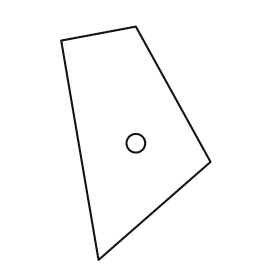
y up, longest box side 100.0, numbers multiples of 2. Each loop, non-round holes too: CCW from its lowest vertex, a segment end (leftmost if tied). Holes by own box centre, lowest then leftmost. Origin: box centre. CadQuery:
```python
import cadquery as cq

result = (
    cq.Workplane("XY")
    .moveTo(-16.0, -50.0)
    .lineTo(32.0, -8.0)
    .lineTo(0.0, 50.0)
    .lineTo(-32.0, 44.0)
    .close()
    .moveTo(0.0, 0.0)
    .circle(4.0)
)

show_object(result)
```